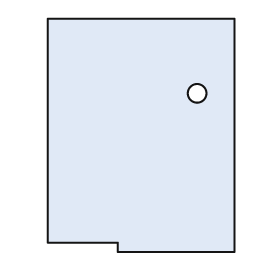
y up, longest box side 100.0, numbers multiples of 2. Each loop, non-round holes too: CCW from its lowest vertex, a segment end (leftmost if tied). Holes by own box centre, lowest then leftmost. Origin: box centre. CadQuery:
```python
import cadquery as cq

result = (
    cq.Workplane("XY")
    .moveTo(-10.0, -50.0)
    .lineTo(40.0, -50.0)
    .lineTo(40.0, 50.0)
    .lineTo(-40.0, 50.0)
    .lineTo(-40.0, -46.0)
    .lineTo(-10.0, -46.0)
    .close()
    .moveTo(24.0, 18.0)
    .circle(4.0)
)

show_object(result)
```